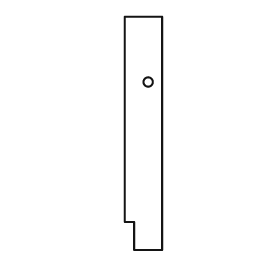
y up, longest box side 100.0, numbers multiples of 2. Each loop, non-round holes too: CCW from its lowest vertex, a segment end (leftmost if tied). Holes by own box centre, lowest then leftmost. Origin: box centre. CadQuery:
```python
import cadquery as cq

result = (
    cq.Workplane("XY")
    .moveTo(-4.0, -50.0)
    .lineTo(8.0, -50.0)
    .lineTo(8.0, 50.0)
    .lineTo(-8.0, 50.0)
    .lineTo(-8.0, -38.0)
    .lineTo(-4.0, -38.0)
    .close()
    .moveTo(2.0, 22.0)
    .circle(2.0)
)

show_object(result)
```